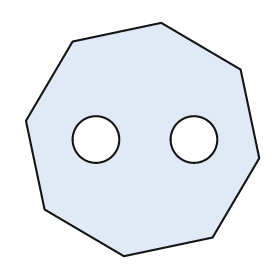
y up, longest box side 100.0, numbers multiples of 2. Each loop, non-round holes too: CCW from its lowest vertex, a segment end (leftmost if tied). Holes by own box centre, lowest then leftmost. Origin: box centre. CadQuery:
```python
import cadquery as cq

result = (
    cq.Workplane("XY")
    .moveTo(-8.0, -50.0)
    .lineTo(30.0, -42.0)
    .lineTo(50.0, -8.0)
    .lineTo(42.0, 30.0)
    .lineTo(8.0, 50.0)
    .lineTo(-30.0, 42.0)
    .lineTo(-50.0, 8.0)
    .lineTo(-42.0, -30.0)
    .close()
    .moveTo(-20.0, 0.0)
    .circle(10.0)
    .moveTo(22.0, 0.0)
    .circle(10.0)
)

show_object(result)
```